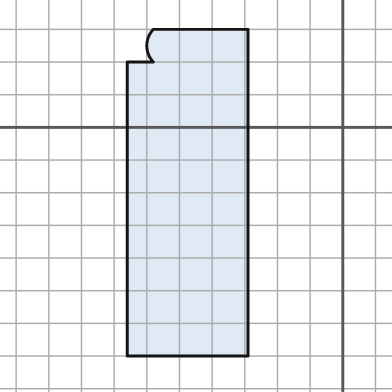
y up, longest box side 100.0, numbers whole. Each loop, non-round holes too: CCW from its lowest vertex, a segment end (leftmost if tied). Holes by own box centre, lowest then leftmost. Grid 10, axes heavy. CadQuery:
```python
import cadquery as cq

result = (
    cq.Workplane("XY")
    .moveTo(-66.0, -70.0)
    .lineTo(-29.0, -70.0)
    .lineTo(-29.0, 30.0)
    .lineTo(-58.0, 30.0)
    .threePointArc((-60.0, 25.0), (-58.0, 20.0))
    .lineTo(-66.0, 20.0)
    .close()
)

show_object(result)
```